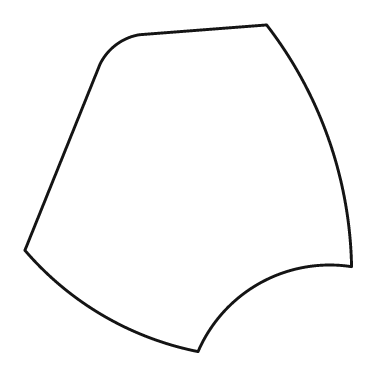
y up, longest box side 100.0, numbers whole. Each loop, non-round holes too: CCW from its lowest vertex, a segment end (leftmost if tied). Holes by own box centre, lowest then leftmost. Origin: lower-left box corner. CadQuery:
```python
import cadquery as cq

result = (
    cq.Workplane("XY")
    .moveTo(53.0, 0.0)
    .threePointArc((72.0, 21.0), (100.0, 26.0))
    .threePointArc((93.0, 65.0), (74.0, 100.0))
    .lineTo(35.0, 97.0)
    .threePointArc((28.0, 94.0), (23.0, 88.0))
    .lineTo(0.0, 31.0)
    .threePointArc((24.0, 11.0), (53.0, 0.0))
    .close()
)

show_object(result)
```